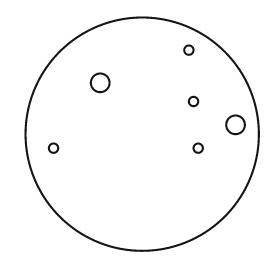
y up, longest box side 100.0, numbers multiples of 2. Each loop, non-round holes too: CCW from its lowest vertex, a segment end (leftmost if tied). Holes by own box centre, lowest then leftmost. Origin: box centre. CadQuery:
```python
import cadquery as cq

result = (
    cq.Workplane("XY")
    .moveTo(0.0, 0.0)
    .circle(50.0)
    .moveTo(-38.0, -6.0)
    .circle(2.0)
    .moveTo(24.0, -6.0)
    .circle(2.0)
    .moveTo(40.0, 4.0)
    .circle(4.0)
    .moveTo(22.0, 14.0)
    .circle(2.0)
    .moveTo(-18.0, 22.0)
    .circle(4.0)
    .moveTo(20.0, 36.0)
    .circle(2.0)
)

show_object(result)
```